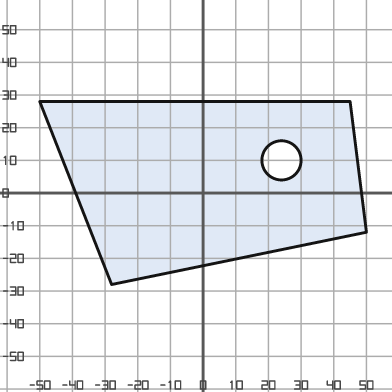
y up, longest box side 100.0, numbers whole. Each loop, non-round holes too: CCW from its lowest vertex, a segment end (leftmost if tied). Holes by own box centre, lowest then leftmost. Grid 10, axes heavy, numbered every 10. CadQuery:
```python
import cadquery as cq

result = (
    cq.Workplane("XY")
    .moveTo(-28.0, -28.0)
    .lineTo(50.0, -12.0)
    .lineTo(45.0, 28.0)
    .lineTo(-50.0, 28.0)
    .close()
    .moveTo(24.0, 10.0)
    .circle(6.0)
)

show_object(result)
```